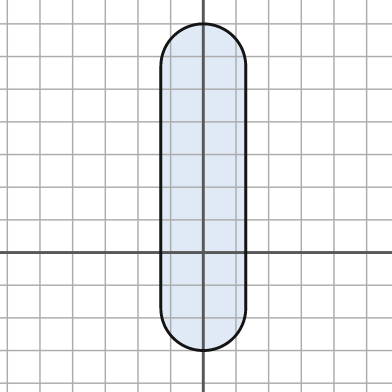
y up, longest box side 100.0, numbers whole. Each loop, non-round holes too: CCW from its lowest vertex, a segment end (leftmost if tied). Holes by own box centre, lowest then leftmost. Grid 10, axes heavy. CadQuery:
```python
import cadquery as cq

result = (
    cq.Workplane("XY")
    .moveTo(-13.0, -17.0)
    .threePointArc((0.0, -30.0), (13.0, -17.0))
    .lineTo(13.0, 57.0)
    .threePointArc((0.0, 70.0), (-13.0, 57.0))
    .close()
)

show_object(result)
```